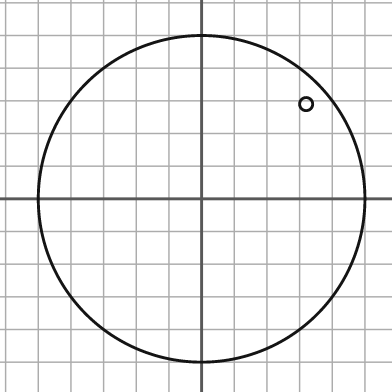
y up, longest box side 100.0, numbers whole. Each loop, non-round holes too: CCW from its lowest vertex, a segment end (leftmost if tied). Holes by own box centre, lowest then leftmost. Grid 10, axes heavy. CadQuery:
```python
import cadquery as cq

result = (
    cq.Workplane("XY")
    .moveTo(0.0, 0.0)
    .circle(50.0)
    .moveTo(32.0, 29.0)
    .circle(2.0)
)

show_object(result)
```